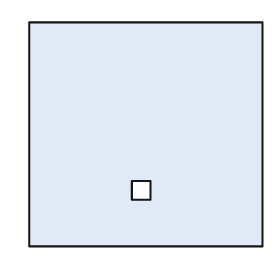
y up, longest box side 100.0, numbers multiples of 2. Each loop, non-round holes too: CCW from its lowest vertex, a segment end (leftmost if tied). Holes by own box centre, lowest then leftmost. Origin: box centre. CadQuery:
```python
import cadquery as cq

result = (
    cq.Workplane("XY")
    .moveTo(-50.0, -48.0)
    .lineTo(50.0, -48.0)
    .lineTo(50.0, 48.0)
    .lineTo(-50.0, 48.0)
    .close()
    .moveTo(-6.0, -28.0)
    .lineTo(2.0, -28.0)
    .lineTo(2.0, -20.0)
    .lineTo(-6.0, -20.0)
    .close()
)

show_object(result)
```